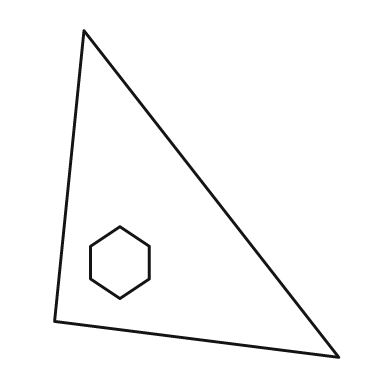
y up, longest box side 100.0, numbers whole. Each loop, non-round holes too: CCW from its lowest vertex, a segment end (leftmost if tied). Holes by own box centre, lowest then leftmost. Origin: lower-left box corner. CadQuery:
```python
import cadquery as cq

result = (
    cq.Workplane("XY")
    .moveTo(87.0, 0.0)
    .lineTo(9.0, 100.0)
    .lineTo(0.0, 11.0)
    .close()
    .moveTo(20.0, 18.0)
    .lineTo(29.0, 24.0)
    .lineTo(29.0, 34.0)
    .lineTo(20.0, 40.0)
    .lineTo(11.0, 34.0)
    .lineTo(11.0, 24.0)
    .close()
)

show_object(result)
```